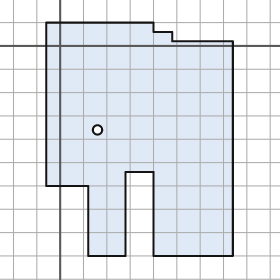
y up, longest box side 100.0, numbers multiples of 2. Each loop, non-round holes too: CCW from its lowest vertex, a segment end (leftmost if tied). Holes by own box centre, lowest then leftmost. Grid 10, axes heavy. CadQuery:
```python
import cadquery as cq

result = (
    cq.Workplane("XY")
    .moveTo(12.0, -90.0)
    .lineTo(28.0, -90.0)
    .lineTo(28.0, -54.0)
    .lineTo(40.0, -54.0)
    .lineTo(40.0, -90.0)
    .lineTo(74.0, -90.0)
    .lineTo(74.0, 2.0)
    .lineTo(48.0, 2.0)
    .lineTo(48.0, 6.0)
    .lineTo(40.0, 6.0)
    .lineTo(40.0, 10.0)
    .lineTo(-6.0, 10.0)
    .lineTo(-6.0, -60.0)
    .lineTo(12.0, -60.0)
    .close()
    .moveTo(16.0, -36.0)
    .circle(2.0)
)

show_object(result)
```